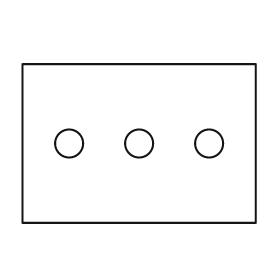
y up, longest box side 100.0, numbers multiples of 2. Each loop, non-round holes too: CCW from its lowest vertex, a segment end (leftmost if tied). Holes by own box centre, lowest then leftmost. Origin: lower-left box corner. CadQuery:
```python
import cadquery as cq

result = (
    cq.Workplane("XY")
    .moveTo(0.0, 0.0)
    .lineTo(100.0, 0.0)
    .lineTo(100.0, 68.0)
    .lineTo(0.0, 68.0)
    .close()
    .moveTo(20.0, 34.0)
    .circle(6.0)
    .moveTo(50.0, 34.0)
    .circle(6.0)
    .moveTo(80.0, 34.0)
    .circle(6.0)
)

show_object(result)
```